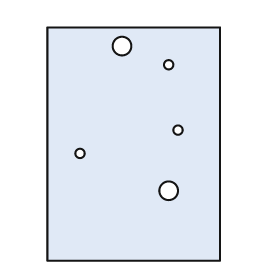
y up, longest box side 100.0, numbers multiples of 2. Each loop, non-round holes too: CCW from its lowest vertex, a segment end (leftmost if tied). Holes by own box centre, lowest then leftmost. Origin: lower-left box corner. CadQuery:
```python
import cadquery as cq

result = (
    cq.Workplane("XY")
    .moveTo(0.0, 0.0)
    .lineTo(74.0, 0.0)
    .lineTo(74.0, 100.0)
    .lineTo(0.0, 100.0)
    .close()
    .moveTo(52.0, 30.0)
    .circle(4.0)
    .moveTo(14.0, 46.0)
    .circle(2.0)
    .moveTo(56.0, 56.0)
    .circle(2.0)
    .moveTo(52.0, 84.0)
    .circle(2.0)
    .moveTo(32.0, 92.0)
    .circle(4.0)
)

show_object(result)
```